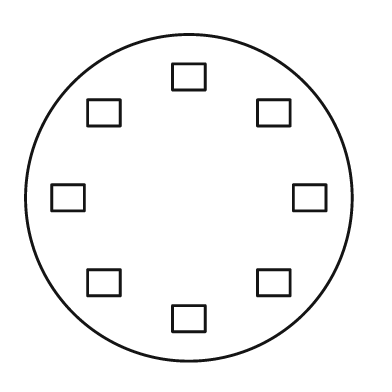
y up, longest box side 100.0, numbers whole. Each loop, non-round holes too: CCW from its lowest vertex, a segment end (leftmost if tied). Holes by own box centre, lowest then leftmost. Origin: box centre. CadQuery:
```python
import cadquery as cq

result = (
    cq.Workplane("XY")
    .moveTo(0.0, 0.0)
    .circle(50.0)
    .moveTo(-5.0, -41.0)
    .lineTo(5.0, -41.0)
    .lineTo(5.0, -33.0)
    .lineTo(-5.0, -33.0)
    .close()
    .moveTo(-31.0, -30.0)
    .lineTo(-21.0, -30.0)
    .lineTo(-21.0, -22.0)
    .lineTo(-31.0, -22.0)
    .close()
    .moveTo(21.0, -30.0)
    .lineTo(31.0, -30.0)
    .lineTo(31.0, -22.0)
    .lineTo(21.0, -22.0)
    .close()
    .moveTo(-42.0, -4.0)
    .lineTo(-32.0, -4.0)
    .lineTo(-32.0, 4.0)
    .lineTo(-42.0, 4.0)
    .close()
    .moveTo(32.0, -4.0)
    .lineTo(42.0, -4.0)
    .lineTo(42.0, 4.0)
    .lineTo(32.0, 4.0)
    .close()
    .moveTo(-31.0, 22.0)
    .lineTo(-21.0, 22.0)
    .lineTo(-21.0, 30.0)
    .lineTo(-31.0, 30.0)
    .close()
    .moveTo(21.0, 22.0)
    .lineTo(31.0, 22.0)
    .lineTo(31.0, 30.0)
    .lineTo(21.0, 30.0)
    .close()
    .moveTo(-5.0, 33.0)
    .lineTo(5.0, 33.0)
    .lineTo(5.0, 41.0)
    .lineTo(-5.0, 41.0)
    .close()
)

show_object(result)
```